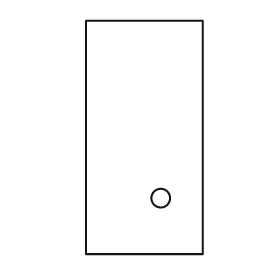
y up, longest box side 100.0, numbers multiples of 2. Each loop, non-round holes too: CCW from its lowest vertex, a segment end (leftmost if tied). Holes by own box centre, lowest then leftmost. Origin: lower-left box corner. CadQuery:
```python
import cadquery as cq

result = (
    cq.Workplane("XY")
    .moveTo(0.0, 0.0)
    .lineTo(50.0, 0.0)
    .lineTo(50.0, 100.0)
    .lineTo(0.0, 100.0)
    .close()
    .moveTo(32.0, 24.0)
    .circle(4.0)
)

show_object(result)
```